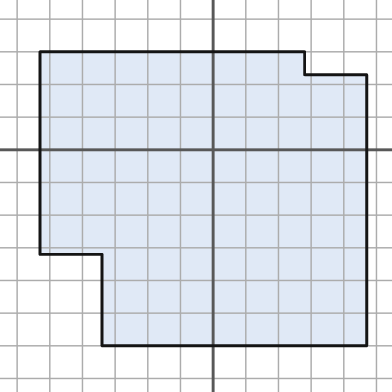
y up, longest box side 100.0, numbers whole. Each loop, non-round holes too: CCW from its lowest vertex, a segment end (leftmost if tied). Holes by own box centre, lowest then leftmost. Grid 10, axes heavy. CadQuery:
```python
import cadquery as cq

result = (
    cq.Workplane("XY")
    .moveTo(-34.0, -60.0)
    .lineTo(47.0, -60.0)
    .lineTo(47.0, 23.0)
    .lineTo(28.0, 23.0)
    .lineTo(28.0, 30.0)
    .lineTo(-53.0, 30.0)
    .lineTo(-53.0, -32.0)
    .lineTo(-34.0, -32.0)
    .close()
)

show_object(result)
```